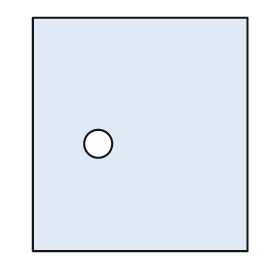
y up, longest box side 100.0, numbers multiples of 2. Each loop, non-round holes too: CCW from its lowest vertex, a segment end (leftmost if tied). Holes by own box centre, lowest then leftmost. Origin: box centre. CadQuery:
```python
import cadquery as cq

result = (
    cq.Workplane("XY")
    .moveTo(-46.0, -50.0)
    .lineTo(46.0, -50.0)
    .lineTo(46.0, 50.0)
    .lineTo(-46.0, 50.0)
    .close()
    .moveTo(-18.0, -4.0)
    .circle(6.0)
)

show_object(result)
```